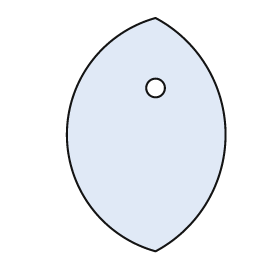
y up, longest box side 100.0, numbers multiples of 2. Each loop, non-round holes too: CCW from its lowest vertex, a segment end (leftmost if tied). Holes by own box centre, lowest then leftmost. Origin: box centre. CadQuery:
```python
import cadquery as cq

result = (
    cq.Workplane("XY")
    .moveTo(4.0, -50.0)
    .threePointArc((34.0, 0.0), (4.0, 50.0))
    .threePointArc((-34.0, 0.0), (4.0, -50.0))
    .close()
    .moveTo(4.0, 20.0)
    .circle(4.0)
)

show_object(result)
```